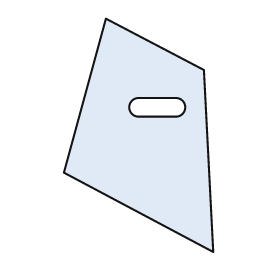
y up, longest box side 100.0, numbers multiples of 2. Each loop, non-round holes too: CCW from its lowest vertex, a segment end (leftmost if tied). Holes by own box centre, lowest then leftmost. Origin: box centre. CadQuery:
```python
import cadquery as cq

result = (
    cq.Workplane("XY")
    .moveTo(32.0, -50.0)
    .lineTo(28.0, 28.0)
    .lineTo(-14.0, 50.0)
    .lineTo(-32.0, -16.0)
    .close()
    .moveTo(0.0, 8.0)
    .lineTo(16.0, 8.0)
    .threePointArc((20.0, 12.0), (16.0, 16.0))
    .lineTo(0.0, 16.0)
    .threePointArc((-4.0, 12.0), (0.0, 8.0))
    .close()
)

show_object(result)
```